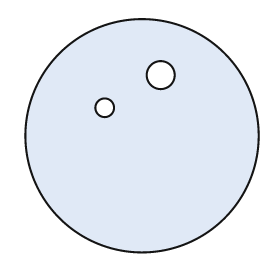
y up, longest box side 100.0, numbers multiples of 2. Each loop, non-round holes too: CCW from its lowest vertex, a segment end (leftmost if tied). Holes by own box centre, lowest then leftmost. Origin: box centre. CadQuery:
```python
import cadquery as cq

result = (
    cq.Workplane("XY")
    .moveTo(0.0, 0.0)
    .circle(50.0)
    .moveTo(-16.0, 12.0)
    .circle(4.0)
    .moveTo(8.0, 26.0)
    .circle(6.0)
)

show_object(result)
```